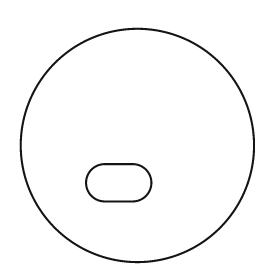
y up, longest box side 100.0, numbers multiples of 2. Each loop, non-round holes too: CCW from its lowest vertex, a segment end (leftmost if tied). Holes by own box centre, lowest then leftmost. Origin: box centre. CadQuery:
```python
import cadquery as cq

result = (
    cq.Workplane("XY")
    .moveTo(0.0, 0.0)
    .circle(50.0)
    .moveTo(-14.0, -24.0)
    .lineTo(-2.0, -24.0)
    .threePointArc((6.0, -16.0), (-2.0, -8.0))
    .lineTo(-14.0, -8.0)
    .threePointArc((-22.0, -16.0), (-14.0, -24.0))
    .close()
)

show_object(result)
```